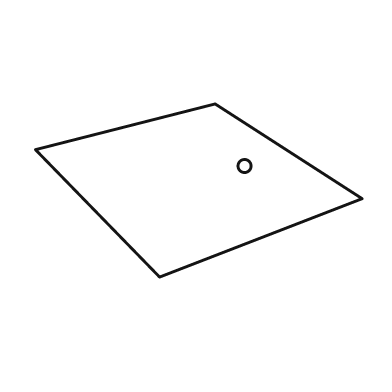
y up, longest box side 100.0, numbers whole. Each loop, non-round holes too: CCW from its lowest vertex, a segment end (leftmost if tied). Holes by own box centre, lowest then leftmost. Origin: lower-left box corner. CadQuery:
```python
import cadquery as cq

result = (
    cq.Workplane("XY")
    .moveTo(38.0, 0.0)
    .lineTo(100.0, 24.0)
    .lineTo(55.0, 53.0)
    .lineTo(0.0, 39.0)
    .close()
    .moveTo(64.0, 34.0)
    .circle(2.0)
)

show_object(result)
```